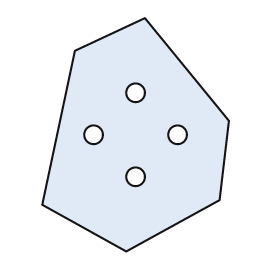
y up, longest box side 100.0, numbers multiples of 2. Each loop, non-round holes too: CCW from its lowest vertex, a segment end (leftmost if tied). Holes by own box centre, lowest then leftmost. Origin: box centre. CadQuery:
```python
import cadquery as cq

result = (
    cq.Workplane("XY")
    .moveTo(-4.0, -50.0)
    .lineTo(36.0, -28.0)
    .lineTo(40.0, 6.0)
    .lineTo(4.0, 50.0)
    .lineTo(-26.0, 36.0)
    .lineTo(-40.0, -30.0)
    .close()
    .moveTo(0.0, -18.0)
    .circle(4.0)
    .moveTo(-18.0, 0.0)
    .circle(4.0)
    .moveTo(18.0, 0.0)
    .circle(4.0)
    .moveTo(0.0, 18.0)
    .circle(4.0)
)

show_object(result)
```